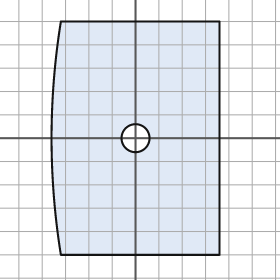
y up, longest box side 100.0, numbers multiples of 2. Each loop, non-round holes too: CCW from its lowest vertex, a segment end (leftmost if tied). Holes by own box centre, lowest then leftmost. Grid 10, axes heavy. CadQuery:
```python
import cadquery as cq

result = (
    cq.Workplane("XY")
    .moveTo(-32.0, -50.0)
    .lineTo(36.0, -50.0)
    .lineTo(36.0, 50.0)
    .lineTo(-32.0, 50.0)
    .threePointArc((-36.0, 0.0), (-32.0, -50.0))
    .close()
    .moveTo(0.0, 0.0)
    .circle(6.0)
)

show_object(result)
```